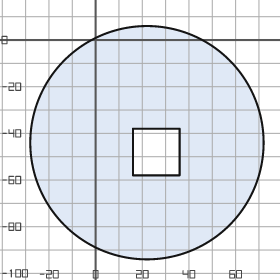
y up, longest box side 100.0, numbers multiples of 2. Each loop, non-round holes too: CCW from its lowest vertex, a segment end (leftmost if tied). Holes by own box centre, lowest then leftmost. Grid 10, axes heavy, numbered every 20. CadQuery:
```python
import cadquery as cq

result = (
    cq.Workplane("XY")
    .moveTo(22.0, -44.0)
    .circle(50.0)
    .moveTo(16.0, -58.0)
    .lineTo(36.0, -58.0)
    .lineTo(36.0, -38.0)
    .lineTo(16.0, -38.0)
    .close()
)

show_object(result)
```